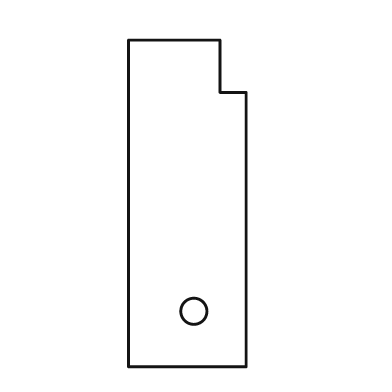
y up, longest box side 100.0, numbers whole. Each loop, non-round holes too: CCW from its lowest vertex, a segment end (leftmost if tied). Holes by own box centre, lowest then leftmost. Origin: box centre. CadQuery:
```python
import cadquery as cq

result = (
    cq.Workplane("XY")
    .moveTo(-18.0, -50.0)
    .lineTo(18.0, -50.0)
    .lineTo(18.0, 34.0)
    .lineTo(10.0, 34.0)
    .lineTo(10.0, 50.0)
    .lineTo(-18.0, 50.0)
    .close()
    .moveTo(2.0, -33.0)
    .circle(4.0)
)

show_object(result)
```